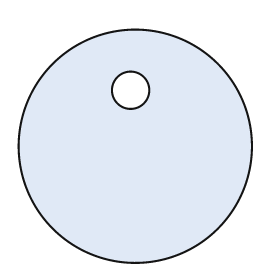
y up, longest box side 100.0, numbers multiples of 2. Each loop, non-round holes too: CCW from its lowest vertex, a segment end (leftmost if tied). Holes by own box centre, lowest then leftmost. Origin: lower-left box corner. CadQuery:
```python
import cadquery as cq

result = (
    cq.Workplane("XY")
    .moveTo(50.0, 50.0)
    .circle(50.0)
    .moveTo(48.0, 74.0)
    .circle(8.0)
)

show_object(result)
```